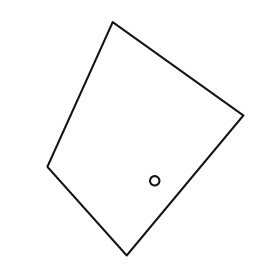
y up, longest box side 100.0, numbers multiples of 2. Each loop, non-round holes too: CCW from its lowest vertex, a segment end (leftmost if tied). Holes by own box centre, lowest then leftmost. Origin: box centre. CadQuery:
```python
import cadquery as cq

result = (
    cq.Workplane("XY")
    .moveTo(-8.0, -50.0)
    .lineTo(42.0, 10.0)
    .lineTo(-14.0, 50.0)
    .lineTo(-42.0, -12.0)
    .close()
    .moveTo(4.0, -18.0)
    .circle(2.0)
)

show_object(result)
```